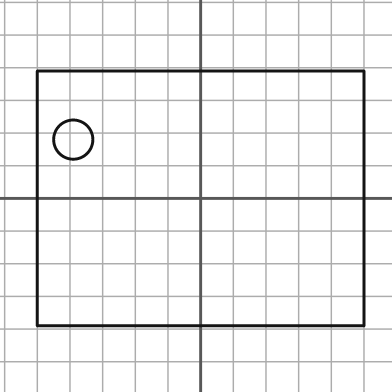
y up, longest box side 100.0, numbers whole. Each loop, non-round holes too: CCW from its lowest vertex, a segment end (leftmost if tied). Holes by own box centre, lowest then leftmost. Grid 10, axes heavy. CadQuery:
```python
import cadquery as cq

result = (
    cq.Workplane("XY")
    .moveTo(-50.0, -39.0)
    .lineTo(50.0, -39.0)
    .lineTo(50.0, 39.0)
    .lineTo(-50.0, 39.0)
    .close()
    .moveTo(-39.0, 18.0)
    .circle(6.0)
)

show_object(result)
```